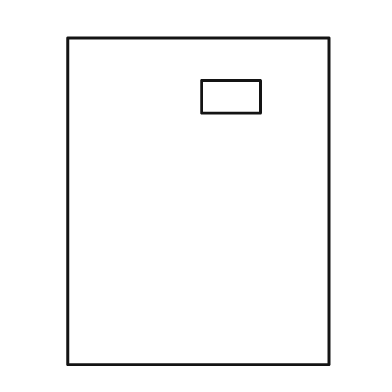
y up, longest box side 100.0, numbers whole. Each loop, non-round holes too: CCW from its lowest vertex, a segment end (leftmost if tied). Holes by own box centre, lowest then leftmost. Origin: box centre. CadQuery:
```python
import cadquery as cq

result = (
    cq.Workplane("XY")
    .moveTo(-40.0, -50.0)
    .lineTo(40.0, -50.0)
    .lineTo(40.0, 50.0)
    .lineTo(-40.0, 50.0)
    .close()
    .moveTo(1.0, 27.0)
    .lineTo(19.0, 27.0)
    .lineTo(19.0, 37.0)
    .lineTo(1.0, 37.0)
    .close()
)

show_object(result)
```